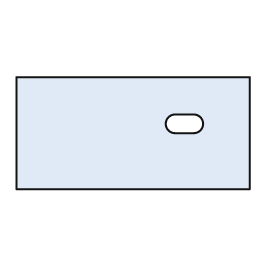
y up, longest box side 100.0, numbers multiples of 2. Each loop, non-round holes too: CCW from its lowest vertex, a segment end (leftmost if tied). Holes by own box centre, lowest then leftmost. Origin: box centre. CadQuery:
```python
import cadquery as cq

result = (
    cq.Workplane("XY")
    .moveTo(-50.0, -24.0)
    .lineTo(50.0, -24.0)
    .lineTo(50.0, 24.0)
    .lineTo(-50.0, 24.0)
    .close()
    .moveTo(18.0, 0.0)
    .lineTo(26.0, 0.0)
    .threePointArc((30.0, 4.0), (26.0, 8.0))
    .lineTo(18.0, 8.0)
    .threePointArc((14.0, 4.0), (18.0, 0.0))
    .close()
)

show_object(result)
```